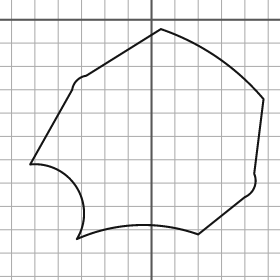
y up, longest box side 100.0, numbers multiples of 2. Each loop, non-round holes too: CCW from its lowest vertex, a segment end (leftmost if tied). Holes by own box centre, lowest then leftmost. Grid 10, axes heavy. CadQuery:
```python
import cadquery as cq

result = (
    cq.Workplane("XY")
    .moveTo(-32.0, -94.0)
    .threePointArc((-6.0, -88.0), (20.0, -92.0))
    .lineTo(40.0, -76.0)
    .threePointArc((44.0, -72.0), (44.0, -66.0))
    .lineTo(48.0, -34.0)
    .threePointArc((28.0, -16.0), (4.0, -4.0))
    .lineTo(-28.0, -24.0)
    .threePointArc((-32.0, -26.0), (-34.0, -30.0))
    .lineTo(-52.0, -62.0)
    .threePointArc((-32.0, -72.0), (-32.0, -94.0))
    .close()
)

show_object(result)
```